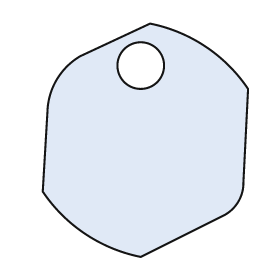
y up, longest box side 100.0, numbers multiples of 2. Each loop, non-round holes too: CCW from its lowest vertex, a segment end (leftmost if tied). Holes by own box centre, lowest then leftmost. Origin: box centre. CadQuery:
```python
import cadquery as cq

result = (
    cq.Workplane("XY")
    .moveTo(-2.0, -50.0)
    .lineTo(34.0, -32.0)
    .threePointArc((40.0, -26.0), (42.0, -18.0))
    .lineTo(44.0, 22.0)
    .threePointArc((26.0, 40.0), (2.0, 50.0))
    .lineTo(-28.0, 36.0)
    .threePointArc((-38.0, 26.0), (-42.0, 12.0))
    .lineTo(-44.0, -22.0)
    .threePointArc((-26.0, -40.0), (-2.0, -50.0))
    .close()
    .moveTo(-2.0, 32.0)
    .circle(10.0)
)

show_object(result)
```